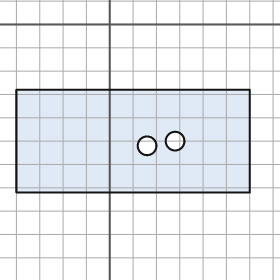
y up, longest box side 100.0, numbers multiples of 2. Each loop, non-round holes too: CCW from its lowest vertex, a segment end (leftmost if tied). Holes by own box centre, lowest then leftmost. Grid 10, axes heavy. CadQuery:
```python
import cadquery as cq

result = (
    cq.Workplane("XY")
    .moveTo(-40.0, -72.0)
    .lineTo(60.0, -72.0)
    .lineTo(60.0, -28.0)
    .lineTo(-40.0, -28.0)
    .close()
    .moveTo(16.0, -52.0)
    .circle(4.0)
    .moveTo(28.0, -50.0)
    .circle(4.0)
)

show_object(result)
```